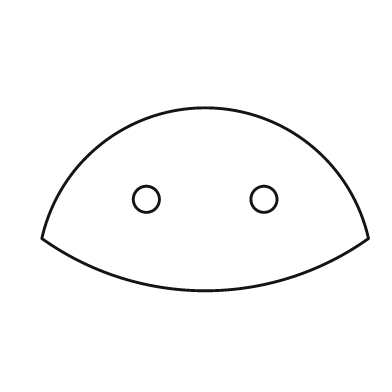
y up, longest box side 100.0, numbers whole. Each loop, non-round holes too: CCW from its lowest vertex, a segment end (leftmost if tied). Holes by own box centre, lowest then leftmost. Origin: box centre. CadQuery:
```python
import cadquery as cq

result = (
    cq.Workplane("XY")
    .moveTo(-50.0, -12.0)
    .threePointArc((0.0, -28.0), (50.0, -12.0))
    .threePointArc((0.0, 28.0), (-50.0, -12.0))
    .close()
    .moveTo(-18.0, 0.0)
    .circle(4.0)
    .moveTo(18.0, 0.0)
    .circle(4.0)
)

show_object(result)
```